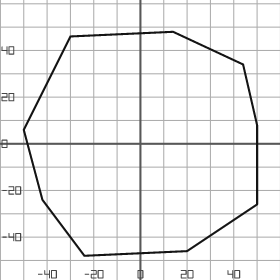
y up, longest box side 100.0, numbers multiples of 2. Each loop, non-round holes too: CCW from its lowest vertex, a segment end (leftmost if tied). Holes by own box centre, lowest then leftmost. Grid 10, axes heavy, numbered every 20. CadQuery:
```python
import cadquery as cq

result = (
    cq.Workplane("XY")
    .moveTo(-24.0, -48.0)
    .lineTo(20.0, -46.0)
    .lineTo(50.0, -26.0)
    .lineTo(50.0, 8.0)
    .lineTo(44.0, 34.0)
    .lineTo(14.0, 48.0)
    .lineTo(-30.0, 46.0)
    .lineTo(-50.0, 6.0)
    .lineTo(-42.0, -24.0)
    .close()
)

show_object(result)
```